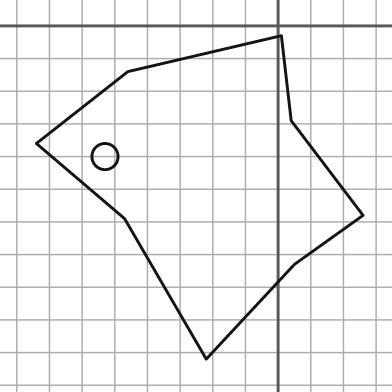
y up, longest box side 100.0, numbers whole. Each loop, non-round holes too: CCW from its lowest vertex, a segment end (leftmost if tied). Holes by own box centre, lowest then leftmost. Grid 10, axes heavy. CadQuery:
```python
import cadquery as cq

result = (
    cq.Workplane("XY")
    .moveTo(-22.0, -102.0)
    .lineTo(5.0, -73.0)
    .lineTo(26.0, -58.0)
    .lineTo(4.0, -29.0)
    .lineTo(1.0, -3.0)
    .lineTo(-46.0, -14.0)
    .lineTo(-74.0, -36.0)
    .lineTo(-47.0, -59.0)
    .close()
    .moveTo(-53.0, -40.0)
    .circle(4.0)
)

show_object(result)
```